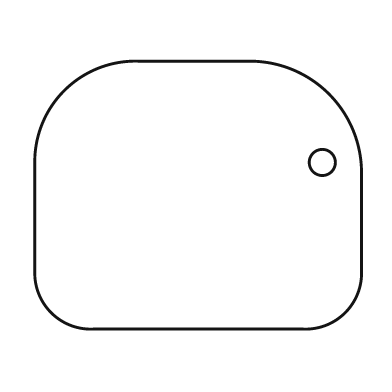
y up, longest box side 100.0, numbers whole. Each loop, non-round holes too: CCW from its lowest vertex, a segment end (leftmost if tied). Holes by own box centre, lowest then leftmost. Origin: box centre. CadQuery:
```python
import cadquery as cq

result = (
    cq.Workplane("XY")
    .moveTo(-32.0, -41.0)
    .lineTo(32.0, -41.0)
    .threePointArc((45.0, -36.0), (50.0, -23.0))
    .lineTo(50.0, 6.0)
    .threePointArc((40.0, 31.0), (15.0, 41.0))
    .lineTo(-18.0, 41.0)
    .threePointArc((-41.0, 32.0), (-50.0, 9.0))
    .lineTo(-50.0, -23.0)
    .threePointArc((-45.0, -36.0), (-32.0, -41.0))
    .close()
    .moveTo(38.0, 10.0)
    .circle(4.0)
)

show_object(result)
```